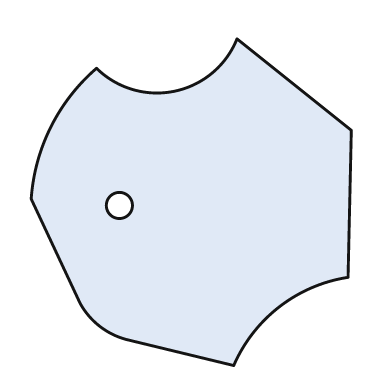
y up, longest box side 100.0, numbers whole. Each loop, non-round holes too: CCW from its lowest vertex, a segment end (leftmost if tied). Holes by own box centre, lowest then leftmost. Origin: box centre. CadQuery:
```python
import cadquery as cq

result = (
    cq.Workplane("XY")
    .moveTo(13.0, -50.0)
    .threePointArc((27.0, -32.0), (48.0, -23.0))
    .lineTo(49.0, 22.0)
    .lineTo(14.0, 50.0)
    .threePointArc((-5.0, 34.0), (-29.0, 41.0))
    .threePointArc((-43.0, 23.0), (-49.0, 1.0))
    .lineTo(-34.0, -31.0)
    .threePointArc((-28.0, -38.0), (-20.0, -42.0))
    .close()
    .moveTo(-22.0, -1.0)
    .circle(4.0)
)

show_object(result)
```